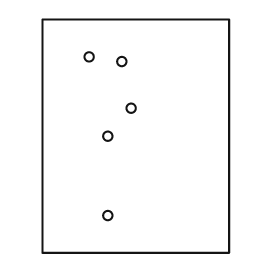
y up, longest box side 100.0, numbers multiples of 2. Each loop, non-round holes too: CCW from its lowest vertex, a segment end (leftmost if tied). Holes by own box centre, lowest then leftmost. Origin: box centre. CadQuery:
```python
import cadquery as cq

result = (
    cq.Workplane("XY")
    .moveTo(-40.0, -50.0)
    .lineTo(40.0, -50.0)
    .lineTo(40.0, 50.0)
    .lineTo(-40.0, 50.0)
    .close()
    .moveTo(-12.0, -34.0)
    .circle(2.0)
    .moveTo(-12.0, 0.0)
    .circle(2.0)
    .moveTo(-2.0, 12.0)
    .circle(2.0)
    .moveTo(-6.0, 32.0)
    .circle(2.0)
    .moveTo(-20.0, 34.0)
    .circle(2.0)
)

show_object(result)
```